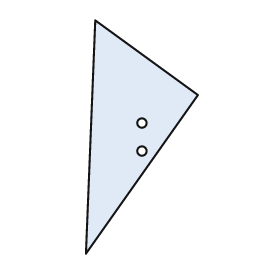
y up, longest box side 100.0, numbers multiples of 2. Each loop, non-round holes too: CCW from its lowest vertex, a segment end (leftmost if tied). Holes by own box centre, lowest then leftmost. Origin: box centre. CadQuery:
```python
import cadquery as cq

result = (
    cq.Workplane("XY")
    .moveTo(-24.0, -50.0)
    .lineTo(24.0, 18.0)
    .lineTo(-20.0, 50.0)
    .close()
    .moveTo(0.0, -6.0)
    .circle(2.0)
    .moveTo(0.0, 6.0)
    .circle(2.0)
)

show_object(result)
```